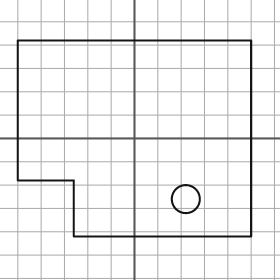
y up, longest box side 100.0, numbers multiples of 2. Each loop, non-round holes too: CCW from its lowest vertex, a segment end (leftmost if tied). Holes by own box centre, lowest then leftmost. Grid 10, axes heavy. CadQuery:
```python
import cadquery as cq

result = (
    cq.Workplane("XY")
    .moveTo(-26.0, -42.0)
    .lineTo(50.0, -42.0)
    .lineTo(50.0, 42.0)
    .lineTo(-50.0, 42.0)
    .lineTo(-50.0, -18.0)
    .lineTo(-26.0, -18.0)
    .close()
    .moveTo(22.0, -26.0)
    .circle(6.0)
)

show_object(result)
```